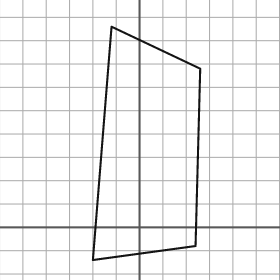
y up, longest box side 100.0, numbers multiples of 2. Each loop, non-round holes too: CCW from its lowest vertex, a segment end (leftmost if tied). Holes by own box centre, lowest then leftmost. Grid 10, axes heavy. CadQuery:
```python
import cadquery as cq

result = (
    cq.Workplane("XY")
    .moveTo(-20.0, -14.0)
    .lineTo(24.0, -8.0)
    .lineTo(26.0, 68.0)
    .lineTo(-12.0, 86.0)
    .close()
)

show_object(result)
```